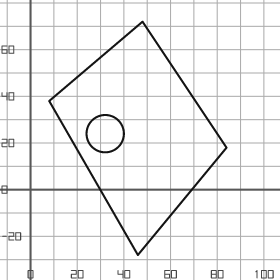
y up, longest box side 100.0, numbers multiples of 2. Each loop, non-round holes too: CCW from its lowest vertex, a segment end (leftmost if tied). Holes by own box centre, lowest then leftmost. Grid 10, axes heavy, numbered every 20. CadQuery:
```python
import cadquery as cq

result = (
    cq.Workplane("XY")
    .moveTo(46.0, -28.0)
    .lineTo(84.0, 18.0)
    .lineTo(48.0, 72.0)
    .lineTo(8.0, 38.0)
    .close()
    .moveTo(32.0, 24.0)
    .circle(8.0)
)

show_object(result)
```